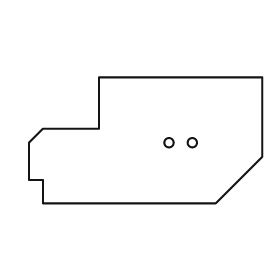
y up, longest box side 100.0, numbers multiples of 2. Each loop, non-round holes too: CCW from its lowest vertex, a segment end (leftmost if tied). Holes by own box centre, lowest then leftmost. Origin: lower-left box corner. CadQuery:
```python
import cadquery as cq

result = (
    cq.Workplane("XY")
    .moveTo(6.0, 0.0)
    .lineTo(80.0, 0.0)
    .lineTo(100.0, 20.0)
    .lineTo(100.0, 54.0)
    .lineTo(30.0, 54.0)
    .lineTo(30.0, 32.0)
    .lineTo(6.0, 32.0)
    .lineTo(0.0, 26.0)
    .lineTo(0.0, 10.0)
    .lineTo(6.0, 10.0)
    .close()
    .moveTo(60.0, 26.0)
    .circle(2.0)
    .moveTo(70.0, 26.0)
    .circle(2.0)
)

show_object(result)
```